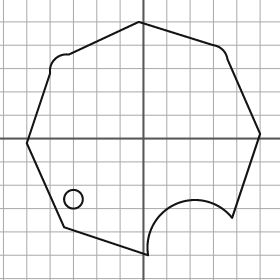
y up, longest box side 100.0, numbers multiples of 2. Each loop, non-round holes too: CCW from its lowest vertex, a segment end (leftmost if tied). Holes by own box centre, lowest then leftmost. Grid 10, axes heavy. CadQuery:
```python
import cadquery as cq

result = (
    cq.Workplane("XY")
    .moveTo(2.0, -50.0)
    .threePointArc((14.0, -28.0), (38.0, -34.0))
    .lineTo(50.0, 2.0)
    .lineTo(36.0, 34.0)
    .threePointArc((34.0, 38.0), (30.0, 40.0))
    .lineTo(-2.0, 50.0)
    .lineTo(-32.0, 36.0)
    .threePointArc((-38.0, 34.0), (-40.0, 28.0))
    .lineTo(-50.0, -2.0)
    .lineTo(-34.0, -38.0)
    .close()
    .moveTo(-30.0, -26.0)
    .circle(4.0)
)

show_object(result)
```